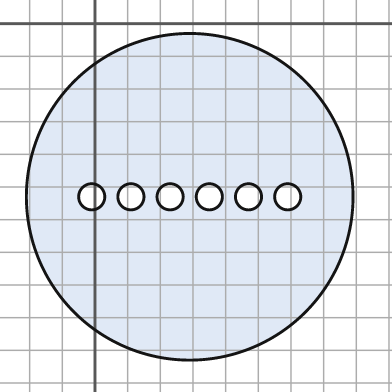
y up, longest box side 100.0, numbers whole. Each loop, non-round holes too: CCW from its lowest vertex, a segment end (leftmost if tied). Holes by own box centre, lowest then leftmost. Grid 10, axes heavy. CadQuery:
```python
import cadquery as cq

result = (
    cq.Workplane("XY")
    .moveTo(29.0, -53.0)
    .circle(50.0)
    .moveTo(-1.0, -53.0)
    .circle(4.0)
    .moveTo(11.0, -53.0)
    .circle(4.0)
    .moveTo(23.0, -53.0)
    .circle(4.0)
    .moveTo(35.0, -53.0)
    .circle(4.0)
    .moveTo(47.0, -53.0)
    .circle(4.0)
    .moveTo(59.0, -53.0)
    .circle(4.0)
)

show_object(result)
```